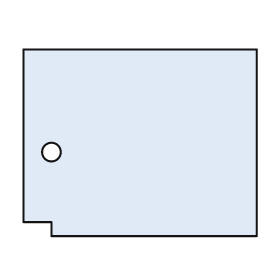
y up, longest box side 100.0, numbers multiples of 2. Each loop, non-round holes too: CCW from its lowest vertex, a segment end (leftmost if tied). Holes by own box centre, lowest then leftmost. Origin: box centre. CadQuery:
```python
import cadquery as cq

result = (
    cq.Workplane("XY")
    .moveTo(-38.0, -40.0)
    .lineTo(50.0, -40.0)
    .lineTo(50.0, 40.0)
    .lineTo(-50.0, 40.0)
    .lineTo(-50.0, -34.0)
    .lineTo(-38.0, -34.0)
    .close()
    .moveTo(-38.0, -4.0)
    .circle(4.0)
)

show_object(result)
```